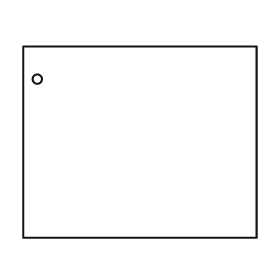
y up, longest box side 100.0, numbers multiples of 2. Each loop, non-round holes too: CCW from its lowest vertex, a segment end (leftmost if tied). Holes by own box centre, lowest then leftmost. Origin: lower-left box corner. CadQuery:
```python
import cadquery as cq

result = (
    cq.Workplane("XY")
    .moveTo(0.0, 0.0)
    .lineTo(100.0, 0.0)
    .lineTo(100.0, 82.0)
    .lineTo(0.0, 82.0)
    .close()
    .moveTo(6.0, 68.0)
    .circle(2.0)
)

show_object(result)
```